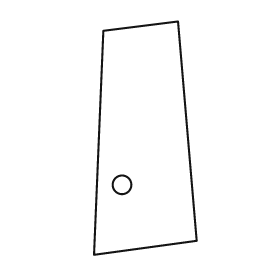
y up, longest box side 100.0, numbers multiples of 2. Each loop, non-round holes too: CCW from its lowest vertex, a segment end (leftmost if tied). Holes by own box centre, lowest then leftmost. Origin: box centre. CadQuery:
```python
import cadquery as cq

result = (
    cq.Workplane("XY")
    .moveTo(-22.0, -50.0)
    .lineTo(22.0, -44.0)
    .lineTo(14.0, 50.0)
    .lineTo(-18.0, 46.0)
    .close()
    .moveTo(-10.0, -20.0)
    .circle(4.0)
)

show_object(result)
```